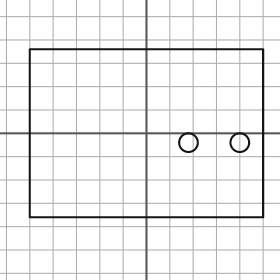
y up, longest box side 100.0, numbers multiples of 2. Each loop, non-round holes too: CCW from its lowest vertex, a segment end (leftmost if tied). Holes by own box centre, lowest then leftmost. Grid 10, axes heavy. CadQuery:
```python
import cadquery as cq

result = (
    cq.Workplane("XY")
    .moveTo(-50.0, -36.0)
    .lineTo(50.0, -36.0)
    .lineTo(50.0, 36.0)
    .lineTo(-50.0, 36.0)
    .close()
    .moveTo(18.0, -4.0)
    .circle(4.0)
    .moveTo(40.0, -4.0)
    .circle(4.0)
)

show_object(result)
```